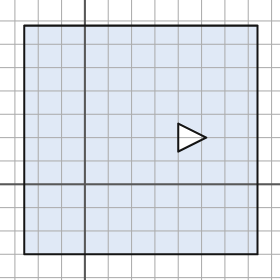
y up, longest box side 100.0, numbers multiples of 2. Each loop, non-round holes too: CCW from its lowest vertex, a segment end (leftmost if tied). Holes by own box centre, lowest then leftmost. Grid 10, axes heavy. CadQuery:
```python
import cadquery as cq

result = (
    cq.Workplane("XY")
    .moveTo(-26.0, -30.0)
    .lineTo(74.0, -30.0)
    .lineTo(74.0, 68.0)
    .lineTo(-26.0, 68.0)
    .close()
    .moveTo(40.0, 14.0)
    .lineTo(52.0, 20.0)
    .lineTo(40.0, 26.0)
    .close()
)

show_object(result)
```